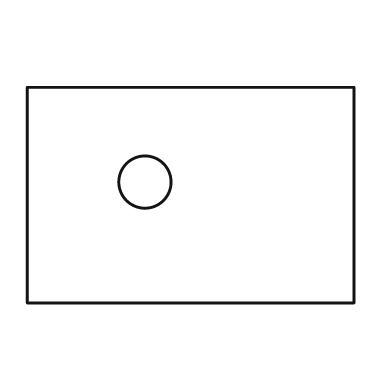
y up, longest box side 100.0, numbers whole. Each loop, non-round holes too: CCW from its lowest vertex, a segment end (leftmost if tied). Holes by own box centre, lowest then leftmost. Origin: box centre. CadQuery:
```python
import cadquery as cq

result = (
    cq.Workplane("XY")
    .moveTo(-50.0, -33.0)
    .lineTo(50.0, -33.0)
    .lineTo(50.0, 33.0)
    .lineTo(-50.0, 33.0)
    .close()
    .moveTo(-14.0, 4.0)
    .circle(8.0)
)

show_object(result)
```